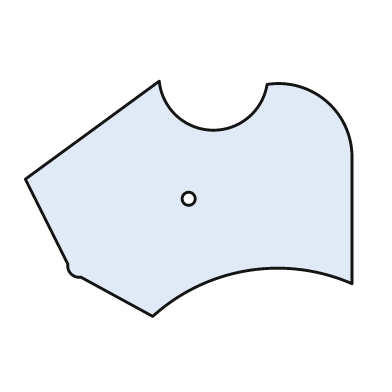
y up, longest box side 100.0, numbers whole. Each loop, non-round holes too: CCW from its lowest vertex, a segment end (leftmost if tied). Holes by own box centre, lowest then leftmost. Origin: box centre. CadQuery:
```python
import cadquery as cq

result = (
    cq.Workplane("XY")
    .moveTo(-11.0, -36.0)
    .threePointArc((18.0, -22.0), (50.0, -26.0))
    .lineTo(50.0, 13.0)
    .threePointArc((42.0, 30.0), (24.0, 35.0))
    .threePointArc((7.0, 21.0), (-9.0, 36.0))
    .lineTo(-50.0, 6.0)
    .lineTo(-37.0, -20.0)
    .threePointArc((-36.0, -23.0), (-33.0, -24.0))
    .close()
    .moveTo(0.0, 0.0)
    .circle(2.0)
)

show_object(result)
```